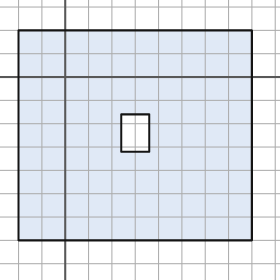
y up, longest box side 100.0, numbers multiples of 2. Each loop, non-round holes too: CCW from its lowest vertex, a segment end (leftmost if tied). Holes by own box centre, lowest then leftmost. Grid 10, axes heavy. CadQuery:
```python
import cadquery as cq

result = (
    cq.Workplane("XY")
    .moveTo(-20.0, -70.0)
    .lineTo(80.0, -70.0)
    .lineTo(80.0, 20.0)
    .lineTo(-20.0, 20.0)
    .close()
    .moveTo(24.0, -32.0)
    .lineTo(36.0, -32.0)
    .lineTo(36.0, -16.0)
    .lineTo(24.0, -16.0)
    .close()
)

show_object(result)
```